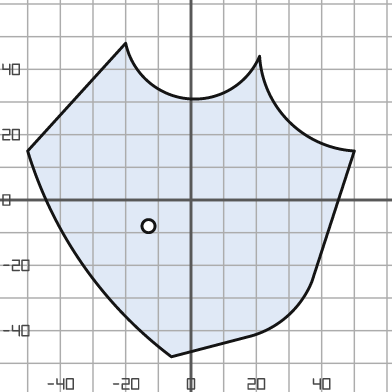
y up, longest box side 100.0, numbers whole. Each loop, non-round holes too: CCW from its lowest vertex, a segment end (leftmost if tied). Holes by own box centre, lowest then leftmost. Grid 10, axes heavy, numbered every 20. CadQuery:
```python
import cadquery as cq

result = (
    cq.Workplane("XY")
    .moveTo(-6.0, -48.0)
    .lineTo(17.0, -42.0)
    .threePointArc((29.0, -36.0), (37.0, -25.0))
    .lineTo(50.0, 15.0)
    .threePointArc((30.0, 24.0), (21.0, 44.0))
    .threePointArc((-1.0, 31.0), (-20.0, 48.0))
    .lineTo(-50.0, 15.0)
    .threePointArc((-33.0, -20.0), (-6.0, -48.0))
    .close()
    .moveTo(-13.0, -8.0)
    .circle(2.0)
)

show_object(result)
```